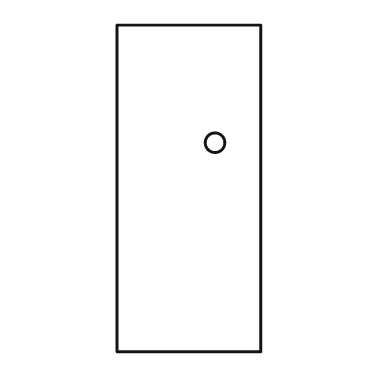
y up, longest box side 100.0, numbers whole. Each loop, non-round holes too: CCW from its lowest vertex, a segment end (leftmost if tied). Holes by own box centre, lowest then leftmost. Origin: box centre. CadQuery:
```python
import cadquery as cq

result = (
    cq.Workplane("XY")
    .moveTo(-22.0, -50.0)
    .lineTo(22.0, -50.0)
    .lineTo(22.0, 50.0)
    .lineTo(-22.0, 50.0)
    .close()
    .moveTo(8.0, 14.0)
    .circle(3.0)
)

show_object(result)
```